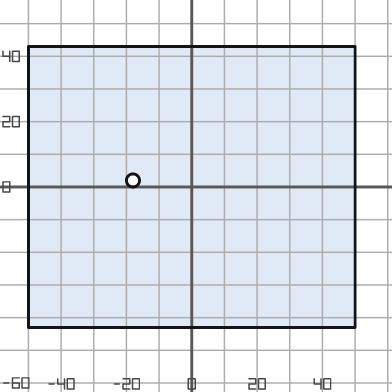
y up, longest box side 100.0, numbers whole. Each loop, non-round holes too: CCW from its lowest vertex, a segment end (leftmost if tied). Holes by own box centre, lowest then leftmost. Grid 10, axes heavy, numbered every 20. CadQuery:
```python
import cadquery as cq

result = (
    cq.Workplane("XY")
    .moveTo(-50.0, -43.0)
    .lineTo(50.0, -43.0)
    .lineTo(50.0, 43.0)
    .lineTo(-50.0, 43.0)
    .close()
    .moveTo(-18.0, 2.0)
    .circle(2.0)
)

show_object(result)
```